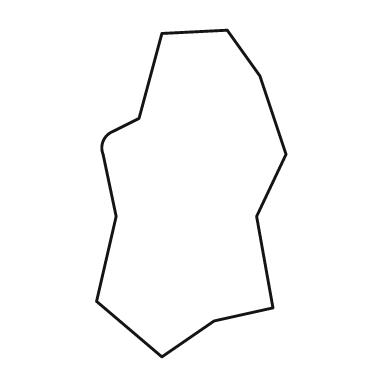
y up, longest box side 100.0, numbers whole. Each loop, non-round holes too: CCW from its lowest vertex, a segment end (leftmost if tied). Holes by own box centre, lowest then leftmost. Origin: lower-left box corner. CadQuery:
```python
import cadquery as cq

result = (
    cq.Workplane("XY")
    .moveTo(20.0, 0.0)
    .lineTo(36.0, 11.0)
    .lineTo(54.0, 15.0)
    .lineTo(49.0, 43.0)
    .lineTo(58.0, 62.0)
    .lineTo(50.0, 86.0)
    .lineTo(40.0, 100.0)
    .lineTo(20.0, 99.0)
    .lineTo(13.0, 73.0)
    .lineTo(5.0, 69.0)
    .threePointArc((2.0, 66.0), (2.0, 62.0))
    .lineTo(6.0, 43.0)
    .lineTo(0.0, 17.0)
    .close()
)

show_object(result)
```